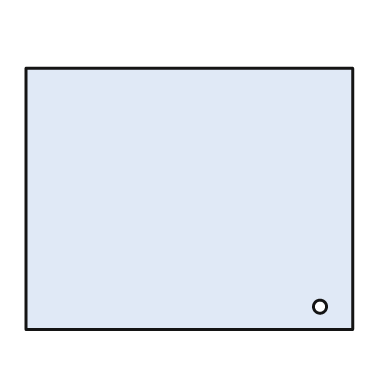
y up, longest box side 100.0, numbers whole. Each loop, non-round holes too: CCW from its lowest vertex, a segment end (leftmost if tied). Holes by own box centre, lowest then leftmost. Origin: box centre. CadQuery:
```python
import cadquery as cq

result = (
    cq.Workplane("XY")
    .moveTo(-50.0, -40.0)
    .lineTo(50.0, -40.0)
    .lineTo(50.0, 40.0)
    .lineTo(-50.0, 40.0)
    .close()
    .moveTo(40.0, -33.0)
    .circle(2.0)
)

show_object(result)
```